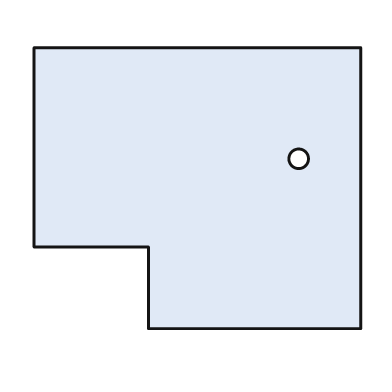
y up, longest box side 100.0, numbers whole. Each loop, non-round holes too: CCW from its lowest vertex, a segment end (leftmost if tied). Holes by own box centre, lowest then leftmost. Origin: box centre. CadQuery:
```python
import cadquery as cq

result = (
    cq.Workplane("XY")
    .moveTo(-15.0, -43.0)
    .lineTo(50.0, -43.0)
    .lineTo(50.0, 43.0)
    .lineTo(-50.0, 43.0)
    .lineTo(-50.0, -18.0)
    .lineTo(-15.0, -18.0)
    .close()
    .moveTo(31.0, 9.0)
    .circle(3.0)
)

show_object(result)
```